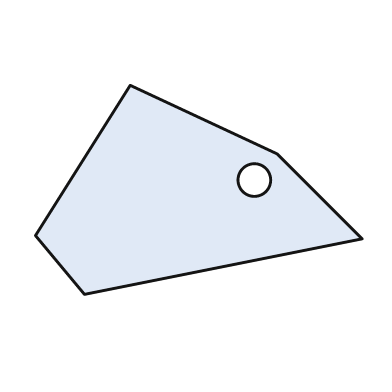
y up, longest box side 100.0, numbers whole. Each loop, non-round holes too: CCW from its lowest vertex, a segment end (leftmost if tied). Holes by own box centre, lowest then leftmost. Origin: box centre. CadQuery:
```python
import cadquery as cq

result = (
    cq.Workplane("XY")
    .moveTo(-35.0, -32.0)
    .lineTo(50.0, -15.0)
    .lineTo(24.0, 11.0)
    .lineTo(-21.0, 32.0)
    .lineTo(-50.0, -14.0)
    .close()
    .moveTo(17.0, 3.0)
    .circle(5.0)
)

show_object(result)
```